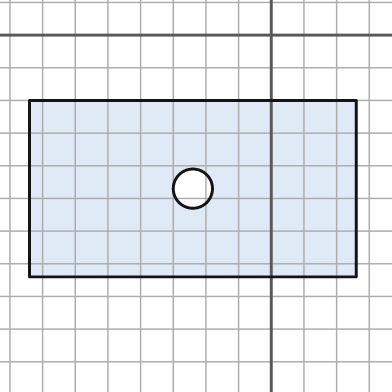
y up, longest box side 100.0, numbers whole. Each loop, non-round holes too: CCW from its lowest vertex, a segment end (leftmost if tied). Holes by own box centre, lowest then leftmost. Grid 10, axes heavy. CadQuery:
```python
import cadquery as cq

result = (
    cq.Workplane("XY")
    .moveTo(-74.0, -74.0)
    .lineTo(26.0, -74.0)
    .lineTo(26.0, -20.0)
    .lineTo(-74.0, -20.0)
    .close()
    .moveTo(-24.0, -47.0)
    .circle(6.0)
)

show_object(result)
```